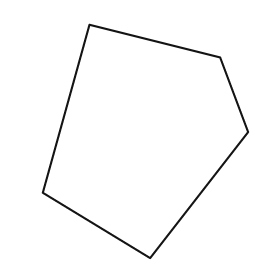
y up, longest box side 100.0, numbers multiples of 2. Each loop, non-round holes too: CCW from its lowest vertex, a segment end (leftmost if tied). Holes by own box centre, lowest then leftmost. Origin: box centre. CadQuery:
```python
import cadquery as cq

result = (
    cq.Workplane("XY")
    .moveTo(2.0, -50.0)
    .lineTo(44.0, 4.0)
    .lineTo(32.0, 36.0)
    .lineTo(-24.0, 50.0)
    .lineTo(-44.0, -22.0)
    .close()
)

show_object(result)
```